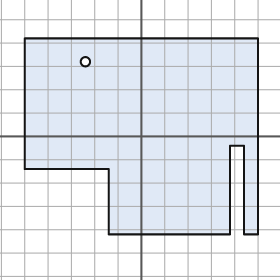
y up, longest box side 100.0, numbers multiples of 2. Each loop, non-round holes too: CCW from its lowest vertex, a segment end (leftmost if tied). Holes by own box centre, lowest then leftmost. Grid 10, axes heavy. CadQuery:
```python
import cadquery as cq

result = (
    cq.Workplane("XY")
    .moveTo(-14.0, -42.0)
    .lineTo(38.0, -42.0)
    .lineTo(38.0, -4.0)
    .lineTo(44.0, -4.0)
    .lineTo(44.0, -42.0)
    .lineTo(50.0, -42.0)
    .lineTo(50.0, 42.0)
    .lineTo(-50.0, 42.0)
    .lineTo(-50.0, -14.0)
    .lineTo(-14.0, -14.0)
    .close()
    .moveTo(-24.0, 32.0)
    .circle(2.0)
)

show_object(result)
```